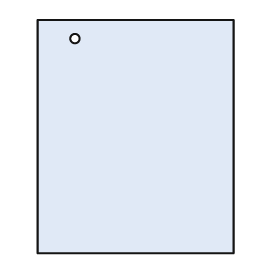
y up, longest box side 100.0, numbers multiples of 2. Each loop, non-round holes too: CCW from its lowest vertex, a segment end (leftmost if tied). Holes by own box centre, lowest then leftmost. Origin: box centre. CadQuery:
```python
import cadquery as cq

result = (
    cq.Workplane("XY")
    .moveTo(-42.0, -50.0)
    .lineTo(42.0, -50.0)
    .lineTo(42.0, 50.0)
    .lineTo(-42.0, 50.0)
    .close()
    .moveTo(-26.0, 42.0)
    .circle(2.0)
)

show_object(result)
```